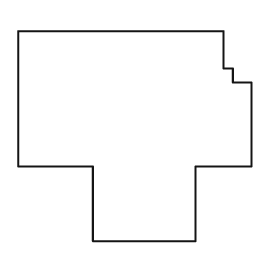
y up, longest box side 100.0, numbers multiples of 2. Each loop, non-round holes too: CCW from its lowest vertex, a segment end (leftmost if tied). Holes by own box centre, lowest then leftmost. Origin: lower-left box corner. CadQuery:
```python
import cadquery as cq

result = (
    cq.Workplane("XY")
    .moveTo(32.0, 0.0)
    .lineTo(76.0, 0.0)
    .lineTo(76.0, 32.0)
    .lineTo(100.0, 32.0)
    .lineTo(100.0, 68.0)
    .lineTo(92.0, 68.0)
    .lineTo(92.0, 74.0)
    .lineTo(88.0, 74.0)
    .lineTo(88.0, 90.0)
    .lineTo(0.0, 90.0)
    .lineTo(0.0, 32.0)
    .lineTo(32.0, 32.0)
    .close()
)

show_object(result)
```